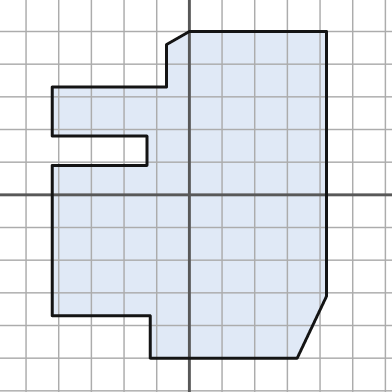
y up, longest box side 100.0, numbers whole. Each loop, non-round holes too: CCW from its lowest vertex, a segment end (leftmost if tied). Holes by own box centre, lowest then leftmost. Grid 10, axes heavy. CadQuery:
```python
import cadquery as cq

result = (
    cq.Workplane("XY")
    .moveTo(-12.0, -50.0)
    .lineTo(33.0, -50.0)
    .lineTo(42.0, -31.0)
    .lineTo(42.0, 50.0)
    .lineTo(0.0, 50.0)
    .lineTo(-7.0, 46.0)
    .lineTo(-7.0, 33.0)
    .lineTo(-42.0, 33.0)
    .lineTo(-42.0, 18.0)
    .lineTo(-13.0, 18.0)
    .lineTo(-13.0, 9.0)
    .lineTo(-42.0, 9.0)
    .lineTo(-42.0, -37.0)
    .lineTo(-12.0, -37.0)
    .close()
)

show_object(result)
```